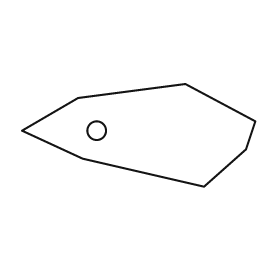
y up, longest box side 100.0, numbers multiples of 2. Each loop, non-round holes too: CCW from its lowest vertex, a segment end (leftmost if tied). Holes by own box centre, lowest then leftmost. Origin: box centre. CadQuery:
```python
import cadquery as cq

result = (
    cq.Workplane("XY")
    .moveTo(28.0, -22.0)
    .lineTo(46.0, -6.0)
    .lineTo(50.0, 6.0)
    .lineTo(20.0, 22.0)
    .lineTo(-26.0, 16.0)
    .lineTo(-50.0, 2.0)
    .lineTo(-24.0, -10.0)
    .close()
    .moveTo(-18.0, 2.0)
    .circle(4.0)
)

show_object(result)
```